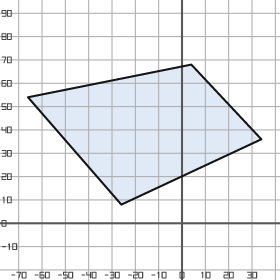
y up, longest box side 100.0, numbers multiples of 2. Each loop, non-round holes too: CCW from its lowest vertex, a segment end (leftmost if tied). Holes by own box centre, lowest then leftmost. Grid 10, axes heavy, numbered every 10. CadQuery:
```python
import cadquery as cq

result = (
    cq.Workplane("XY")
    .moveTo(-26.0, 8.0)
    .lineTo(34.0, 36.0)
    .lineTo(4.0, 68.0)
    .lineTo(-66.0, 54.0)
    .close()
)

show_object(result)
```